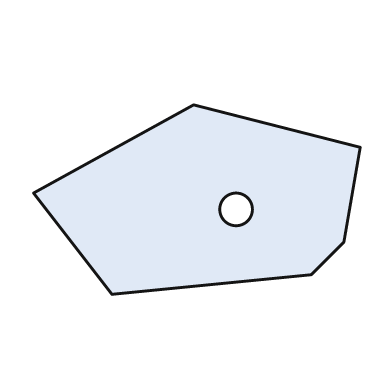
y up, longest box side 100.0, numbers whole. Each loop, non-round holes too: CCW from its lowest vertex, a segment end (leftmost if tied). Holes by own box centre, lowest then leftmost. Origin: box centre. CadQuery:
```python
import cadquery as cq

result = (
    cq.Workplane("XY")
    .moveTo(-26.0, -29.0)
    .lineTo(35.0, -23.0)
    .lineTo(45.0, -13.0)
    .lineTo(50.0, 16.0)
    .lineTo(-1.0, 29.0)
    .lineTo(-50.0, 2.0)
    .close()
    .moveTo(12.0, -3.0)
    .circle(5.0)
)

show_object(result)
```